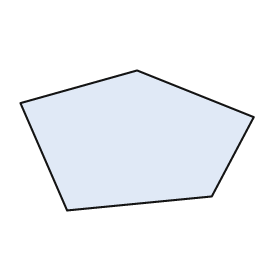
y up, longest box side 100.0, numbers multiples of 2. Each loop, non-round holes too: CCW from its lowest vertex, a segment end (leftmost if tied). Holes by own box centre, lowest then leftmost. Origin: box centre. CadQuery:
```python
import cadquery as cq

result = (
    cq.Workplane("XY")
    .moveTo(-30.0, -30.0)
    .lineTo(32.0, -24.0)
    .lineTo(50.0, 10.0)
    .lineTo(0.0, 30.0)
    .lineTo(-50.0, 16.0)
    .close()
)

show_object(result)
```